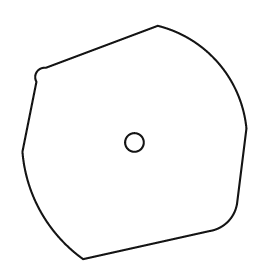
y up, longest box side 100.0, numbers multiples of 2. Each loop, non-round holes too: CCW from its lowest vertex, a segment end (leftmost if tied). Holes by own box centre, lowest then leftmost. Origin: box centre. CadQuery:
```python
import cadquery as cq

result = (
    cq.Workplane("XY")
    .moveTo(-22.0, -50.0)
    .lineTo(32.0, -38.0)
    .threePointArc((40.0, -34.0), (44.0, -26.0))
    .lineTo(48.0, 6.0)
    .threePointArc((36.0, 34.0), (10.0, 50.0))
    .lineTo(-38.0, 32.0)
    .threePointArc((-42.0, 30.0), (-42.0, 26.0))
    .lineTo(-48.0, -4.0)
    .threePointArc((-40.0, -30.0), (-22.0, -50.0))
    .close()
    .moveTo(0.0, 0.0)
    .circle(4.0)
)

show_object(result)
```